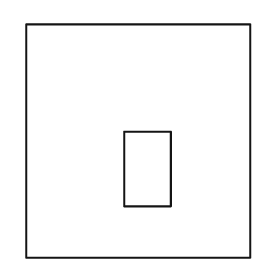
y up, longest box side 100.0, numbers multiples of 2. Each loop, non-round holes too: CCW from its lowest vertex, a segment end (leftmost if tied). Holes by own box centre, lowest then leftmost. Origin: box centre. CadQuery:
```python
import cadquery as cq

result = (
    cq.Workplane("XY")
    .moveTo(-48.0, -50.0)
    .lineTo(48.0, -50.0)
    .lineTo(48.0, 50.0)
    .lineTo(-48.0, 50.0)
    .close()
    .moveTo(-6.0, -28.0)
    .lineTo(14.0, -28.0)
    .lineTo(14.0, 4.0)
    .lineTo(-6.0, 4.0)
    .close()
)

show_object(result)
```